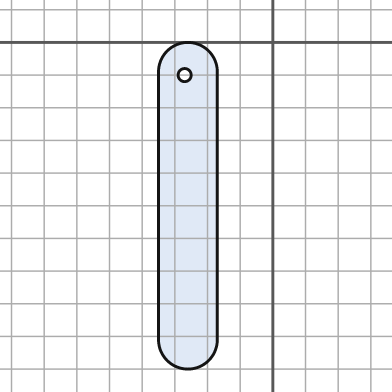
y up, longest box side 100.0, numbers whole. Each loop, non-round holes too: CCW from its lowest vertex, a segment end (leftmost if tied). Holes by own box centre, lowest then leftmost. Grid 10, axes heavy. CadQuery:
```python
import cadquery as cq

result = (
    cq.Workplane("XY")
    .moveTo(-35.0, -91.0)
    .threePointArc((-26.0, -100.0), (-17.0, -91.0))
    .lineTo(-17.0, -9.0)
    .threePointArc((-26.0, 0.0), (-35.0, -9.0))
    .close()
    .moveTo(-27.0, -10.0)
    .circle(2.0)
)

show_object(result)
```